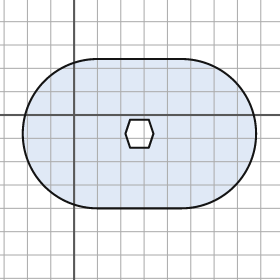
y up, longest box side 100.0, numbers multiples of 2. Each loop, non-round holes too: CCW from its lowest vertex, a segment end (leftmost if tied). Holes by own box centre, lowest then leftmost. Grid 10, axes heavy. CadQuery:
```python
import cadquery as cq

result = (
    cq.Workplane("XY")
    .moveTo(10.0, -40.0)
    .lineTo(46.0, -40.0)
    .threePointArc((78.0, -8.0), (46.0, 24.0))
    .lineTo(10.0, 24.0)
    .threePointArc((-22.0, -8.0), (10.0, -40.0))
    .close()
    .moveTo(24.0, -14.0)
    .lineTo(32.0, -14.0)
    .lineTo(34.0, -8.0)
    .lineTo(32.0, -2.0)
    .lineTo(24.0, -2.0)
    .lineTo(22.0, -8.0)
    .close()
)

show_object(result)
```